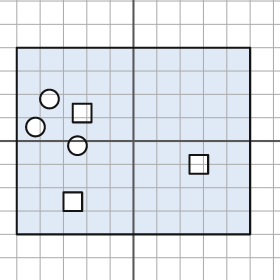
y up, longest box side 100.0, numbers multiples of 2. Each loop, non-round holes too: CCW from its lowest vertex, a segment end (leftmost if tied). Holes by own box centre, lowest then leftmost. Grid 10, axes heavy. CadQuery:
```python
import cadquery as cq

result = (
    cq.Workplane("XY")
    .moveTo(-50.0, -40.0)
    .lineTo(50.0, -40.0)
    .lineTo(50.0, 40.0)
    .lineTo(-50.0, 40.0)
    .close()
    .moveTo(-30.0, -30.0)
    .lineTo(-22.0, -30.0)
    .lineTo(-22.0, -22.0)
    .lineTo(-30.0, -22.0)
    .close()
    .moveTo(24.0, -14.0)
    .lineTo(32.0, -14.0)
    .lineTo(32.0, -6.0)
    .lineTo(24.0, -6.0)
    .close()
    .moveTo(-24.0, -2.0)
    .circle(4.0)
    .moveTo(-42.0, 6.0)
    .circle(4.0)
    .moveTo(-26.0, 8.0)
    .lineTo(-18.0, 8.0)
    .lineTo(-18.0, 16.0)
    .lineTo(-26.0, 16.0)
    .close()
    .moveTo(-36.0, 18.0)
    .circle(4.0)
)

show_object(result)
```